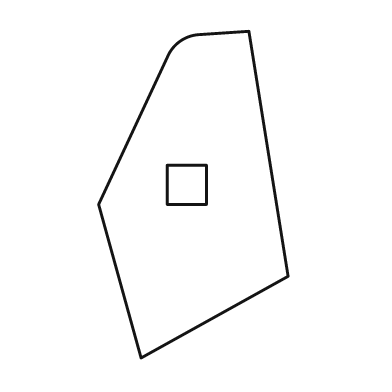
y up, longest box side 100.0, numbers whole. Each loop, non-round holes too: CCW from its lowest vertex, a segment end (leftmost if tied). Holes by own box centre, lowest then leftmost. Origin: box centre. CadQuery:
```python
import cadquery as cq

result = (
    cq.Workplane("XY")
    .moveTo(-16.0, -50.0)
    .lineTo(29.0, -25.0)
    .lineTo(17.0, 50.0)
    .lineTo(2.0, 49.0)
    .threePointArc((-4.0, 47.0), (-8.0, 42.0))
    .lineTo(-29.0, -3.0)
    .close()
    .moveTo(-8.0, -3.0)
    .lineTo(4.0, -3.0)
    .lineTo(4.0, 9.0)
    .lineTo(-8.0, 9.0)
    .close()
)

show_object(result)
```